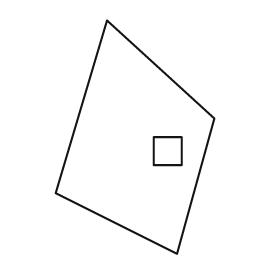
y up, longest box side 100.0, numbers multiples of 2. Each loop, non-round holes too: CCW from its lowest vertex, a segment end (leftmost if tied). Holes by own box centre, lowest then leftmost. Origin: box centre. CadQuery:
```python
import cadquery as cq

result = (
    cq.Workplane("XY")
    .moveTo(18.0, -50.0)
    .lineTo(34.0, 8.0)
    .lineTo(-12.0, 50.0)
    .lineTo(-34.0, -24.0)
    .close()
    .moveTo(8.0, -12.0)
    .lineTo(20.0, -12.0)
    .lineTo(20.0, 0.0)
    .lineTo(8.0, 0.0)
    .close()
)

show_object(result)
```